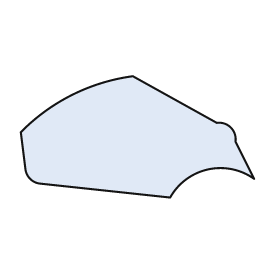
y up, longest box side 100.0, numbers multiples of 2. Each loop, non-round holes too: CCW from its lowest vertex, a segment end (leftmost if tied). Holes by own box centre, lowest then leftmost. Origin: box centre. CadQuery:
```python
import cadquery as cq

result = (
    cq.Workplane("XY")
    .moveTo(14.0, -26.0)
    .threePointArc((30.0, -14.0), (50.0, -18.0))
    .lineTo(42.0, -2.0)
    .threePointArc((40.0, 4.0), (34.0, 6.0))
    .lineTo(-2.0, 26.0)
    .threePointArc((-28.0, 18.0), (-50.0, 2.0))
    .lineTo(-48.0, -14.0)
    .threePointArc((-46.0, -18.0), (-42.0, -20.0))
    .close()
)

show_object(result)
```